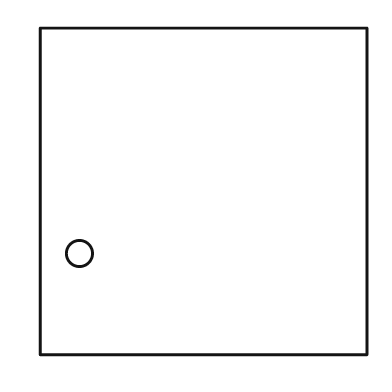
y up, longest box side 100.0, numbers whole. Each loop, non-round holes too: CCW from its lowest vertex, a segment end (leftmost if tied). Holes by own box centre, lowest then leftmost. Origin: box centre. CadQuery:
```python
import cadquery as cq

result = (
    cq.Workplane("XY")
    .moveTo(-50.0, -50.0)
    .lineTo(50.0, -50.0)
    .lineTo(50.0, 50.0)
    .lineTo(-50.0, 50.0)
    .close()
    .moveTo(-38.0, -19.0)
    .circle(4.0)
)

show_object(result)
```